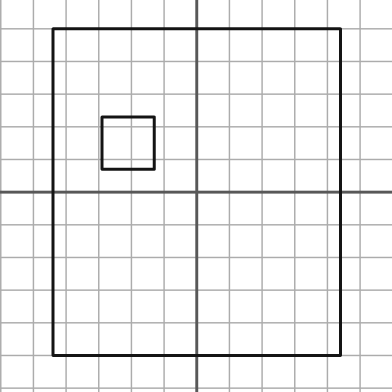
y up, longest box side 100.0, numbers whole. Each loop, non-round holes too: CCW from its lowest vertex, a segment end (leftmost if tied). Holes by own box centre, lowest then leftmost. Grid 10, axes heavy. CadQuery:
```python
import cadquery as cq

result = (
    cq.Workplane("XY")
    .moveTo(-44.0, -50.0)
    .lineTo(44.0, -50.0)
    .lineTo(44.0, 50.0)
    .lineTo(-44.0, 50.0)
    .close()
    .moveTo(-29.0, 7.0)
    .lineTo(-13.0, 7.0)
    .lineTo(-13.0, 23.0)
    .lineTo(-29.0, 23.0)
    .close()
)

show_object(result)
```